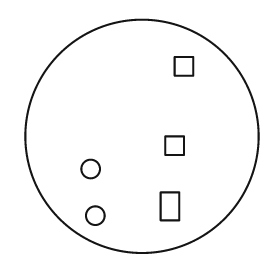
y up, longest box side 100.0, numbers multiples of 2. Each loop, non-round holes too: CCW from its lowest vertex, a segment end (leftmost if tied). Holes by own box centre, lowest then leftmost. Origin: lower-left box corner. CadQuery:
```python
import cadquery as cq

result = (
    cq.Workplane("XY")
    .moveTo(50.0, 50.0)
    .circle(50.0)
    .moveTo(30.0, 16.0)
    .circle(4.0)
    .moveTo(58.0, 14.0)
    .lineTo(66.0, 14.0)
    .lineTo(66.0, 26.0)
    .lineTo(58.0, 26.0)
    .close()
    .moveTo(28.0, 36.0)
    .circle(4.0)
    .moveTo(60.0, 42.0)
    .lineTo(68.0, 42.0)
    .lineTo(68.0, 50.0)
    .lineTo(60.0, 50.0)
    .close()
    .moveTo(64.0, 76.0)
    .lineTo(72.0, 76.0)
    .lineTo(72.0, 84.0)
    .lineTo(64.0, 84.0)
    .close()
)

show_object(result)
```